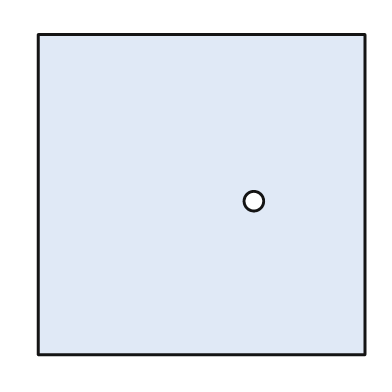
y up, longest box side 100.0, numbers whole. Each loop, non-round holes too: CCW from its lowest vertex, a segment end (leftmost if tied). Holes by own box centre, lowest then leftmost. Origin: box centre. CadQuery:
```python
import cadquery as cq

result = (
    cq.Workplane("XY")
    .moveTo(-50.0, -49.0)
    .lineTo(50.0, -49.0)
    .lineTo(50.0, 49.0)
    .lineTo(-50.0, 49.0)
    .close()
    .moveTo(16.0, -2.0)
    .circle(3.0)
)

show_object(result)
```